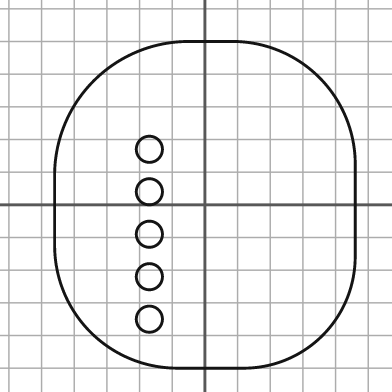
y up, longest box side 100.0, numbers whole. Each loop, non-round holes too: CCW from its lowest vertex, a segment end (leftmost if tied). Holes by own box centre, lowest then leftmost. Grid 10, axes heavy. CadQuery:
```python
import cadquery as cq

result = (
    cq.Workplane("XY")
    .moveTo(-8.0, -50.0)
    .lineTo(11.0, -50.0)
    .threePointArc((36.0, -40.0), (46.0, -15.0))
    .lineTo(46.0, 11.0)
    .threePointArc((35.0, 39.0), (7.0, 50.0))
    .lineTo(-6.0, 50.0)
    .threePointArc((-34.0, 38.0), (-46.0, 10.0))
    .lineTo(-46.0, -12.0)
    .threePointArc((-35.0, -39.0), (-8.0, -50.0))
    .close()
    .moveTo(-17.0, -35.0)
    .circle(4.0)
    .moveTo(-17.0, -22.0)
    .circle(4.0)
    .moveTo(-17.0, -9.0)
    .circle(4.0)
    .moveTo(-17.0, 4.0)
    .circle(4.0)
    .moveTo(-17.0, 17.0)
    .circle(4.0)
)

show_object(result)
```